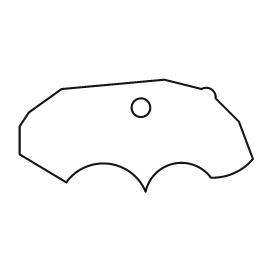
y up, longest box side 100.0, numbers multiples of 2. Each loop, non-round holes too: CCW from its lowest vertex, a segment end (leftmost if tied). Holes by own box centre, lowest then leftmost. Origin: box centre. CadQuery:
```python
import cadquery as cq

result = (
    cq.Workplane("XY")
    .moveTo(4.0, -24.0)
    .threePointArc((16.0, -12.0), (32.0, -18.0))
    .threePointArc((42.0, -16.0), (50.0, -10.0))
    .lineTo(44.0, 6.0)
    .lineTo(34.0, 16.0)
    .threePointArc((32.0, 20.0), (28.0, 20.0))
    .lineTo(12.0, 24.0)
    .lineTo(-32.0, 20.0)
    .lineTo(-46.0, 10.0)
    .lineTo(-50.0, 4.0)
    .lineTo(-50.0, -8.0)
    .lineTo(-30.0, -20.0)
    .threePointArc((-12.0, -12.0), (4.0, -24.0))
    .close()
    .moveTo(2.0, 12.0)
    .circle(4.0)
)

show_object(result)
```